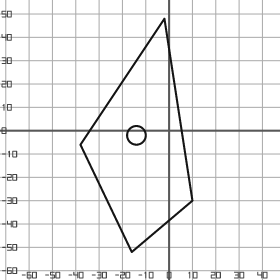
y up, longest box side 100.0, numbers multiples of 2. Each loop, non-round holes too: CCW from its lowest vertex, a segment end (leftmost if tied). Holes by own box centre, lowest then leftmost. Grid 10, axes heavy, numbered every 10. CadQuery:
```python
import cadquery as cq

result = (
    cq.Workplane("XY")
    .moveTo(-16.0, -52.0)
    .lineTo(10.0, -30.0)
    .lineTo(-2.0, 48.0)
    .lineTo(-38.0, -6.0)
    .close()
    .moveTo(-14.0, -2.0)
    .circle(4.0)
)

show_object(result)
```